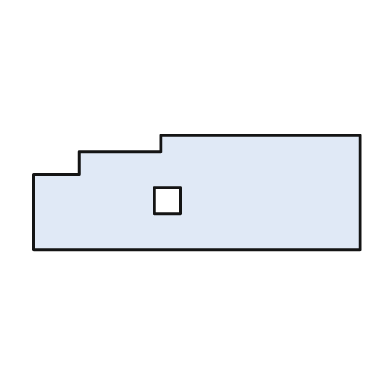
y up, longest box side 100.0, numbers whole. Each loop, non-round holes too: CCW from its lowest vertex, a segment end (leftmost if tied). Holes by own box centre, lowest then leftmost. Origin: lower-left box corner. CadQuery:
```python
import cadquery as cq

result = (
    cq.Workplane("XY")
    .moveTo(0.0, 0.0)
    .lineTo(100.0, 0.0)
    .lineTo(100.0, 35.0)
    .lineTo(39.0, 35.0)
    .lineTo(39.0, 30.0)
    .lineTo(14.0, 30.0)
    .lineTo(14.0, 23.0)
    .lineTo(0.0, 23.0)
    .close()
    .moveTo(37.0, 11.0)
    .lineTo(45.0, 11.0)
    .lineTo(45.0, 19.0)
    .lineTo(37.0, 19.0)
    .close()
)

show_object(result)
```